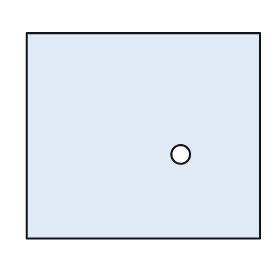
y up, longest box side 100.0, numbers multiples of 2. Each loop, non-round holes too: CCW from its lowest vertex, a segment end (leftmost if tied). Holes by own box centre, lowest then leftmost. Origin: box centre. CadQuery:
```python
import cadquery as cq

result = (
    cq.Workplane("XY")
    .moveTo(-50.0, -44.0)
    .lineTo(50.0, -44.0)
    .lineTo(50.0, 44.0)
    .lineTo(-50.0, 44.0)
    .close()
    .moveTo(16.0, -8.0)
    .circle(4.0)
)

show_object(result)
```